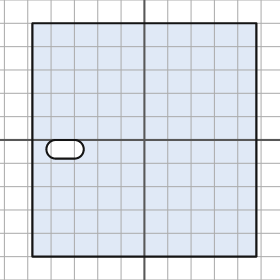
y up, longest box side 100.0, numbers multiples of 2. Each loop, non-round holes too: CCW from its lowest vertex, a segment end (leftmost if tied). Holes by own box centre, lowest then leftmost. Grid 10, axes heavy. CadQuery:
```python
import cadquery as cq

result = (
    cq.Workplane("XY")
    .moveTo(-48.0, -50.0)
    .lineTo(48.0, -50.0)
    .lineTo(48.0, 50.0)
    .lineTo(-48.0, 50.0)
    .close()
    .moveTo(-38.0, -8.0)
    .lineTo(-30.0, -8.0)
    .threePointArc((-26.0, -4.0), (-30.0, 0.0))
    .lineTo(-38.0, 0.0)
    .threePointArc((-42.0, -4.0), (-38.0, -8.0))
    .close()
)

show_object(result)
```